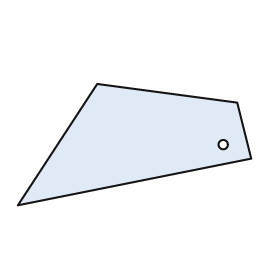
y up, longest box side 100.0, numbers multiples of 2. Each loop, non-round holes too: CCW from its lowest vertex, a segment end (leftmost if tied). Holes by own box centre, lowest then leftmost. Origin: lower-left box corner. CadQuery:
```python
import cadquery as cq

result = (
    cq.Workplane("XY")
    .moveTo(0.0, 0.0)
    .lineTo(100.0, 20.0)
    .lineTo(94.0, 44.0)
    .lineTo(34.0, 52.0)
    .close()
    .moveTo(88.0, 26.0)
    .circle(2.0)
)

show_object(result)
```